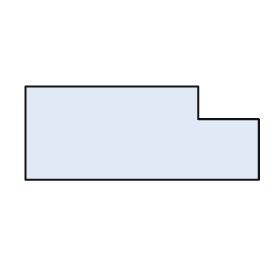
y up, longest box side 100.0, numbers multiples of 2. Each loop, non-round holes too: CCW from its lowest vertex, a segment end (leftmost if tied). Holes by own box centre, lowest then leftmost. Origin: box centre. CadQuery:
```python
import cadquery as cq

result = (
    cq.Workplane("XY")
    .moveTo(-50.0, -20.0)
    .lineTo(50.0, -20.0)
    .lineTo(50.0, 6.0)
    .lineTo(24.0, 6.0)
    .lineTo(24.0, 20.0)
    .lineTo(-50.0, 20.0)
    .close()
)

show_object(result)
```